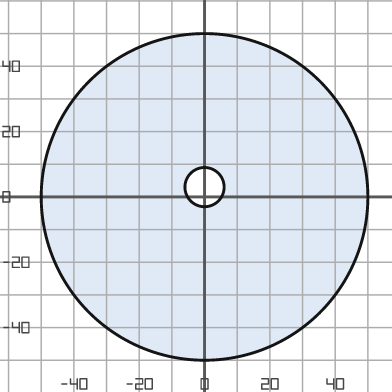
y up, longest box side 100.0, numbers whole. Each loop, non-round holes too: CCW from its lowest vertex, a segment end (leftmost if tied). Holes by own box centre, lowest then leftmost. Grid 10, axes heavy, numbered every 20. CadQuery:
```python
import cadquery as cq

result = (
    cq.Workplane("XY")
    .moveTo(0.0, 0.0)
    .circle(50.0)
    .moveTo(0.0, 3.0)
    .circle(6.0)
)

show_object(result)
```